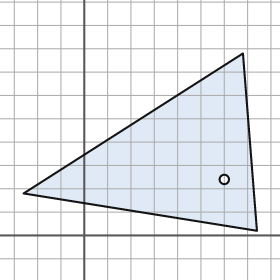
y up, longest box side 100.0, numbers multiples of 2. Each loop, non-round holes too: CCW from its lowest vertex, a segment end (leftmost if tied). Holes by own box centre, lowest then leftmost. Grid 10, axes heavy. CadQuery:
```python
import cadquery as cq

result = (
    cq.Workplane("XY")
    .moveTo(74.0, 2.0)
    .lineTo(68.0, 78.0)
    .lineTo(-26.0, 18.0)
    .close()
    .moveTo(60.0, 24.0)
    .circle(2.0)
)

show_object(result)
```